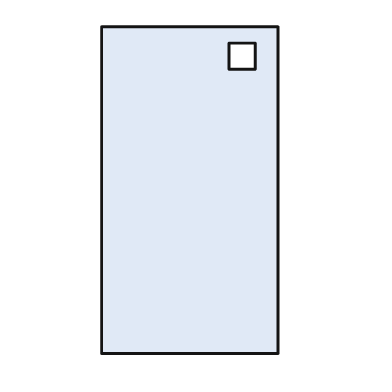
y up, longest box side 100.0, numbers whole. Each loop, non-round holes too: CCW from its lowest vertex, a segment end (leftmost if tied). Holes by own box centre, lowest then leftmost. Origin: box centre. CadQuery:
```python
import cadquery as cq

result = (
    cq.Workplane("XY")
    .moveTo(-27.0, -50.0)
    .lineTo(27.0, -50.0)
    .lineTo(27.0, 50.0)
    .lineTo(-27.0, 50.0)
    .close()
    .moveTo(12.0, 37.0)
    .lineTo(20.0, 37.0)
    .lineTo(20.0, 45.0)
    .lineTo(12.0, 45.0)
    .close()
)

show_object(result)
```